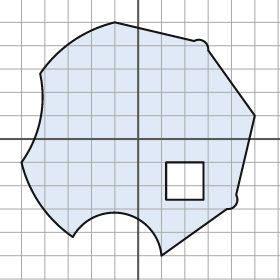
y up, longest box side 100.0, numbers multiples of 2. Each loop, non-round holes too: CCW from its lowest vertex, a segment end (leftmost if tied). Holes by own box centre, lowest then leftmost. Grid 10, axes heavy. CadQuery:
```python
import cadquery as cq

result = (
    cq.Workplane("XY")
    .moveTo(10.0, -50.0)
    .lineTo(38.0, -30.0)
    .threePointArc((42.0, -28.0), (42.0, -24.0))
    .lineTo(50.0, 10.0)
    .lineTo(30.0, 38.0)
    .threePointArc((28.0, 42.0), (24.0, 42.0))
    .lineTo(-10.0, 50.0)
    .threePointArc((-28.0, 42.0), (-42.0, 28.0))
    .threePointArc((-42.0, 8.0), (-50.0, -10.0))
    .threePointArc((-42.0, -28.0), (-28.0, -42.0))
    .threePointArc((-6.0, -32.0), (10.0, -50.0))
    .close()
    .moveTo(12.0, -26.0)
    .lineTo(28.0, -26.0)
    .lineTo(28.0, -10.0)
    .lineTo(12.0, -10.0)
    .close()
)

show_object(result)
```